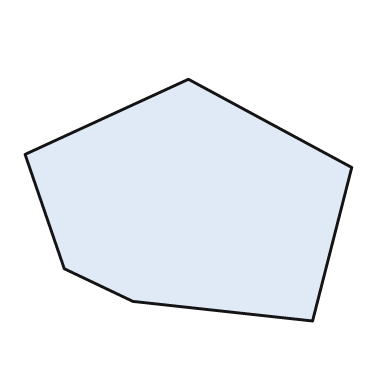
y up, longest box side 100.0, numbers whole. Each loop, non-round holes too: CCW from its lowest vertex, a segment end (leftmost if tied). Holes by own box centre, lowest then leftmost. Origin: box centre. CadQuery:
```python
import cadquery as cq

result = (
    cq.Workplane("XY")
    .moveTo(38.0, -37.0)
    .lineTo(50.0, 10.0)
    .lineTo(0.0, 37.0)
    .lineTo(-50.0, 14.0)
    .lineTo(-38.0, -21.0)
    .lineTo(-17.0, -31.0)
    .close()
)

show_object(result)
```